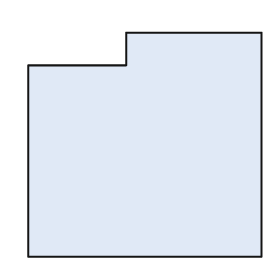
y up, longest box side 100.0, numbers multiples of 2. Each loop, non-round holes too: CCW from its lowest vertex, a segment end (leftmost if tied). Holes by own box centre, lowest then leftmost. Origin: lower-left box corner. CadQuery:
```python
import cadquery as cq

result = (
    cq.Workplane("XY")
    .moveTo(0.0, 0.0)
    .lineTo(100.0, 0.0)
    .lineTo(100.0, 96.0)
    .lineTo(42.0, 96.0)
    .lineTo(42.0, 82.0)
    .lineTo(0.0, 82.0)
    .close()
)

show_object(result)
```